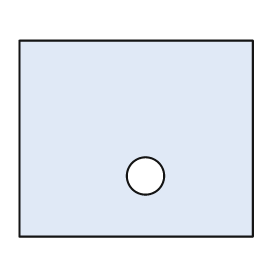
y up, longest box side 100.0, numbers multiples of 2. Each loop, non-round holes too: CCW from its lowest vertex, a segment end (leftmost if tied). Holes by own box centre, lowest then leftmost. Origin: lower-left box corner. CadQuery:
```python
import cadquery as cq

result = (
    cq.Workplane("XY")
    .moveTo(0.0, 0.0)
    .lineTo(100.0, 0.0)
    .lineTo(100.0, 84.0)
    .lineTo(0.0, 84.0)
    .close()
    .moveTo(54.0, 26.0)
    .circle(8.0)
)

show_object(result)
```